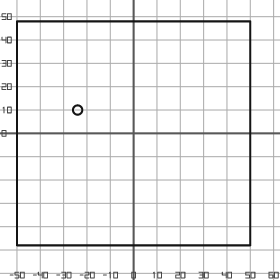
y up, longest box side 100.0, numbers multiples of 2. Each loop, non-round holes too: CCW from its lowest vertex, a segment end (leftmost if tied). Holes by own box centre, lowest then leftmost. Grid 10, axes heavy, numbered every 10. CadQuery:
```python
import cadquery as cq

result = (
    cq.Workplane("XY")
    .moveTo(-50.0, -48.0)
    .lineTo(50.0, -48.0)
    .lineTo(50.0, 48.0)
    .lineTo(-50.0, 48.0)
    .close()
    .moveTo(-24.0, 10.0)
    .circle(2.0)
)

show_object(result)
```